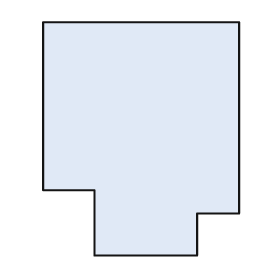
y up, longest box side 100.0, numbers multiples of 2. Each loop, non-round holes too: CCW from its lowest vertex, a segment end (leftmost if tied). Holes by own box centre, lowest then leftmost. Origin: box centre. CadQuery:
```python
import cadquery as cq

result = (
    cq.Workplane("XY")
    .moveTo(-20.0, -50.0)
    .lineTo(24.0, -50.0)
    .lineTo(24.0, -32.0)
    .lineTo(42.0, -32.0)
    .lineTo(42.0, 50.0)
    .lineTo(-42.0, 50.0)
    .lineTo(-42.0, -22.0)
    .lineTo(-20.0, -22.0)
    .close()
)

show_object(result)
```